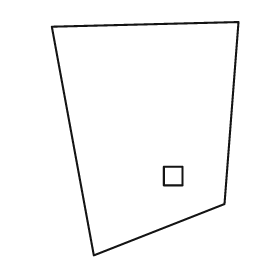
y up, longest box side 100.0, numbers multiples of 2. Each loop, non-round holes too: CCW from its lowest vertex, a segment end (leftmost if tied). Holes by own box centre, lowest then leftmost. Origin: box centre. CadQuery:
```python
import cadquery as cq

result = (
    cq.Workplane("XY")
    .moveTo(-22.0, -50.0)
    .lineTo(34.0, -28.0)
    .lineTo(40.0, 50.0)
    .lineTo(-40.0, 48.0)
    .close()
    .moveTo(8.0, -20.0)
    .lineTo(16.0, -20.0)
    .lineTo(16.0, -12.0)
    .lineTo(8.0, -12.0)
    .close()
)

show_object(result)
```